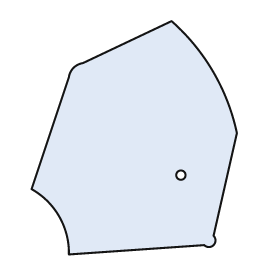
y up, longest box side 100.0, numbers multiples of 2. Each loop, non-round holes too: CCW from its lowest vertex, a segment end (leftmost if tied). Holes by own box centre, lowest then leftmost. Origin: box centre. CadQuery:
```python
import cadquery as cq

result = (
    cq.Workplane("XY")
    .moveTo(-28.0, -50.0)
    .lineTo(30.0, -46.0)
    .threePointArc((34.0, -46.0), (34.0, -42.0))
    .lineTo(44.0, 2.0)
    .threePointArc((34.0, 28.0), (16.0, 50.0))
    .lineTo(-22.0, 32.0)
    .threePointArc((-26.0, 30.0), (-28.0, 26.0))
    .lineTo(-44.0, -22.0)
    .threePointArc((-32.0, -34.0), (-28.0, -50.0))
    .close()
    .moveTo(20.0, -16.0)
    .circle(2.0)
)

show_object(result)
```